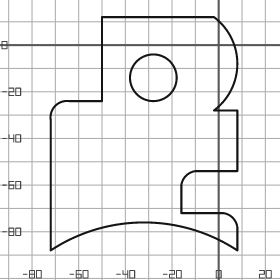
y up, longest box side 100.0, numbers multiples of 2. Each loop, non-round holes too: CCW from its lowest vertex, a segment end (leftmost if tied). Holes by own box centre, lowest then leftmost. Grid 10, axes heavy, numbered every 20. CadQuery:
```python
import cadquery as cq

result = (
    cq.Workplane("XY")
    .moveTo(-72.0, -88.0)
    .threePointArc((-32.0, -76.0), (8.0, -88.0))
    .lineTo(8.0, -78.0)
    .threePointArc((6.0, -74.0), (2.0, -72.0))
    .lineTo(-16.0, -72.0)
    .lineTo(-16.0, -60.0)
    .threePointArc((-14.0, -56.0), (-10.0, -54.0))
    .lineTo(8.0, -54.0)
    .lineTo(8.0, -28.0)
    .lineTo(-2.0, -28.0)
    .threePointArc((8.0, -8.0), (-2.0, 12.0))
    .lineTo(-50.0, 12.0)
    .lineTo(-50.0, -24.0)
    .lineTo(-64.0, -24.0)
    .threePointArc((-70.0, -26.0), (-72.0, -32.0))
    .close()
    .moveTo(-28.0, -14.0)
    .circle(10.0)
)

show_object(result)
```